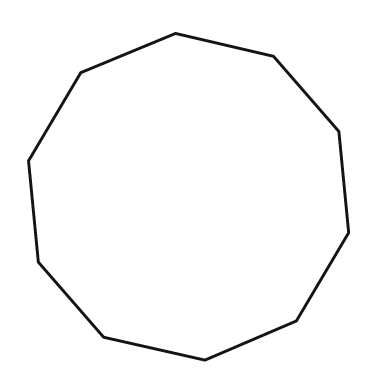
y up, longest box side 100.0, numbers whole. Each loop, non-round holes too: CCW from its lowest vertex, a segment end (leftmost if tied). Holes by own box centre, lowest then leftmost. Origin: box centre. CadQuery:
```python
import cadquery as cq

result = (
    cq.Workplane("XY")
    .moveTo(5.0, -50.0)
    .lineTo(33.0, -38.0)
    .lineTo(49.0, -11.0)
    .lineTo(46.0, 20.0)
    .lineTo(26.0, 43.0)
    .lineTo(-4.0, 50.0)
    .lineTo(-33.0, 38.0)
    .lineTo(-49.0, 11.0)
    .lineTo(-46.0, -20.0)
    .lineTo(-26.0, -43.0)
    .close()
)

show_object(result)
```